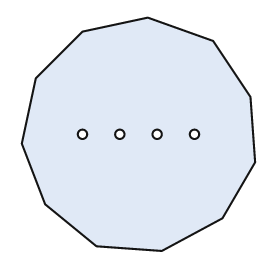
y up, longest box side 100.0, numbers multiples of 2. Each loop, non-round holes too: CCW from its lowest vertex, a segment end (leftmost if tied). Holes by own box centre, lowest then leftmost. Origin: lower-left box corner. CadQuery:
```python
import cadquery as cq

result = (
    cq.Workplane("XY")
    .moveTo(60.0, 0.0)
    .lineTo(86.0, 14.0)
    .lineTo(100.0, 38.0)
    .lineTo(98.0, 66.0)
    .lineTo(82.0, 90.0)
    .lineTo(54.0, 100.0)
    .lineTo(26.0, 94.0)
    .lineTo(6.0, 74.0)
    .lineTo(0.0, 46.0)
    .lineTo(10.0, 20.0)
    .lineTo(32.0, 2.0)
    .close()
    .moveTo(26.0, 50.0)
    .circle(2.0)
    .moveTo(42.0, 50.0)
    .circle(2.0)
    .moveTo(58.0, 50.0)
    .circle(2.0)
    .moveTo(74.0, 50.0)
    .circle(2.0)
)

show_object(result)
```